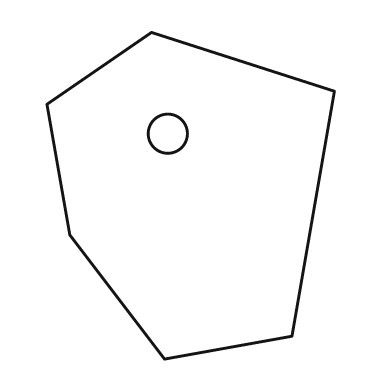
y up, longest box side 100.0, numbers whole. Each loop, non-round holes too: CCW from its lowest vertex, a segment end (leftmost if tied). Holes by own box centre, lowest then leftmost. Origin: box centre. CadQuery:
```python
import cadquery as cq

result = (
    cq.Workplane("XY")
    .moveTo(-8.0, -50.0)
    .lineTo(31.0, -43.0)
    .lineTo(44.0, 32.0)
    .lineTo(-12.0, 50.0)
    .lineTo(-44.0, 28.0)
    .lineTo(-37.0, -12.0)
    .close()
    .moveTo(-7.0, 19.0)
    .circle(6.0)
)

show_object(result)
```